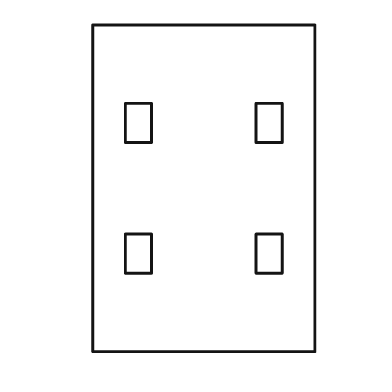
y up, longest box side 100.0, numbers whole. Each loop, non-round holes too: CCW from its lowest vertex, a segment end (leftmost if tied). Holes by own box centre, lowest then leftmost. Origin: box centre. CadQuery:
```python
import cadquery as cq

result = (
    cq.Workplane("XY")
    .moveTo(-34.0, -50.0)
    .lineTo(34.0, -50.0)
    .lineTo(34.0, 50.0)
    .lineTo(-34.0, 50.0)
    .close()
    .moveTo(-24.0, -26.0)
    .lineTo(-16.0, -26.0)
    .lineTo(-16.0, -14.0)
    .lineTo(-24.0, -14.0)
    .close()
    .moveTo(16.0, -26.0)
    .lineTo(24.0, -26.0)
    .lineTo(24.0, -14.0)
    .lineTo(16.0, -14.0)
    .close()
    .moveTo(-24.0, 14.0)
    .lineTo(-16.0, 14.0)
    .lineTo(-16.0, 26.0)
    .lineTo(-24.0, 26.0)
    .close()
    .moveTo(16.0, 14.0)
    .lineTo(24.0, 14.0)
    .lineTo(24.0, 26.0)
    .lineTo(16.0, 26.0)
    .close()
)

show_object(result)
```